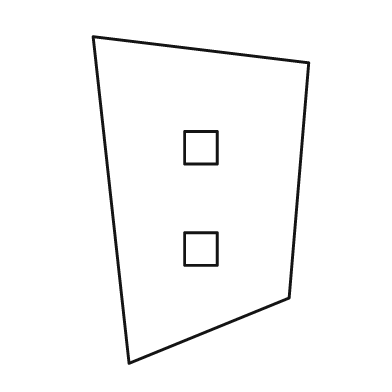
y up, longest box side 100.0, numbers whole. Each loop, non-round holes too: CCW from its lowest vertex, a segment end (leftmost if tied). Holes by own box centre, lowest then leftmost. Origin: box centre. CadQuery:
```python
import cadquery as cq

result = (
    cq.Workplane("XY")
    .moveTo(-22.0, -50.0)
    .lineTo(27.0, -30.0)
    .lineTo(33.0, 42.0)
    .lineTo(-33.0, 50.0)
    .close()
    .moveTo(-5.0, -20.0)
    .lineTo(5.0, -20.0)
    .lineTo(5.0, -10.0)
    .lineTo(-5.0, -10.0)
    .close()
    .moveTo(-5.0, 11.0)
    .lineTo(5.0, 11.0)
    .lineTo(5.0, 21.0)
    .lineTo(-5.0, 21.0)
    .close()
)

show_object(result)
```